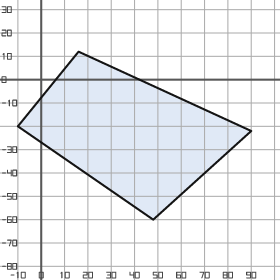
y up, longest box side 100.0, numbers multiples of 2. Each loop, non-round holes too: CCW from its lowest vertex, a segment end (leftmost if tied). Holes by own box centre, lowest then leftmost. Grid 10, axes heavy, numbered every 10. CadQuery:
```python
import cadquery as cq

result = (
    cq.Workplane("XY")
    .moveTo(48.0, -60.0)
    .lineTo(90.0, -22.0)
    .lineTo(16.0, 12.0)
    .lineTo(-10.0, -20.0)
    .close()
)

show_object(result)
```